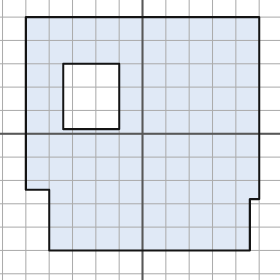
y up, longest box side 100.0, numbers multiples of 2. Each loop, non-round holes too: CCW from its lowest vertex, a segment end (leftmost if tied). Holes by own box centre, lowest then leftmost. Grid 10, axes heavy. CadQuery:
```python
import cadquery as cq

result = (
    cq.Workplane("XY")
    .moveTo(-40.0, -50.0)
    .lineTo(46.0, -50.0)
    .lineTo(46.0, -28.0)
    .lineTo(50.0, -28.0)
    .lineTo(50.0, 50.0)
    .lineTo(-50.0, 50.0)
    .lineTo(-50.0, -24.0)
    .lineTo(-40.0, -24.0)
    .close()
    .moveTo(-34.0, 2.0)
    .lineTo(-10.0, 2.0)
    .lineTo(-10.0, 30.0)
    .lineTo(-34.0, 30.0)
    .close()
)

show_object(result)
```